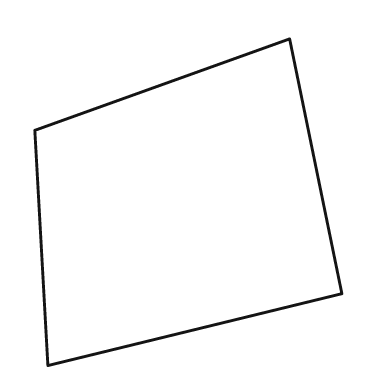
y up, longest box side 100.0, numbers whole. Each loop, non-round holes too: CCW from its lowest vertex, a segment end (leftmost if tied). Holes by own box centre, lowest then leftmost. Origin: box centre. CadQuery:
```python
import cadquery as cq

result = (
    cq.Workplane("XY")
    .moveTo(-43.0, -50.0)
    .lineTo(47.0, -28.0)
    .lineTo(31.0, 50.0)
    .lineTo(-47.0, 22.0)
    .close()
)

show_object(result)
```